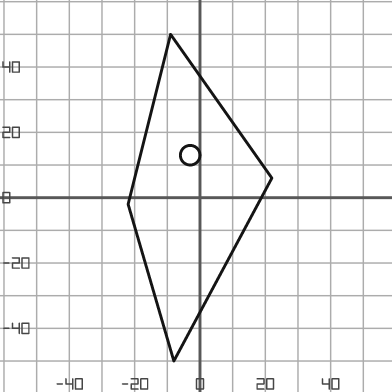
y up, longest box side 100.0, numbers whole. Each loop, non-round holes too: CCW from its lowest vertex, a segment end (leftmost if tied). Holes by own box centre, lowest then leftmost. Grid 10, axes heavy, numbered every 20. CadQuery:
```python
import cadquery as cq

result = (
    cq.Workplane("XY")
    .moveTo(-8.0, -50.0)
    .lineTo(22.0, 6.0)
    .lineTo(-9.0, 50.0)
    .lineTo(-22.0, -2.0)
    .close()
    .moveTo(-3.0, 13.0)
    .circle(3.0)
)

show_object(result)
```